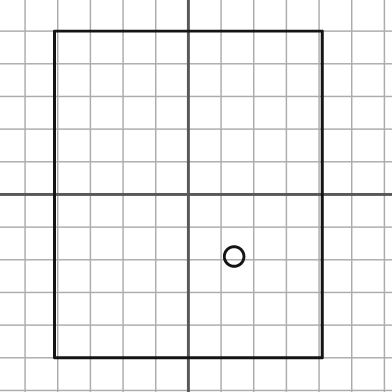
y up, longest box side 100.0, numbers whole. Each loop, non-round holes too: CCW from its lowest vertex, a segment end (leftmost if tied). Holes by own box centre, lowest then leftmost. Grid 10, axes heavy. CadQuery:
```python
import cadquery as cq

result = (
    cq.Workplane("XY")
    .moveTo(-41.0, -50.0)
    .lineTo(41.0, -50.0)
    .lineTo(41.0, 50.0)
    .lineTo(-41.0, 50.0)
    .close()
    .moveTo(14.0, -19.0)
    .circle(3.0)
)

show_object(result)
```